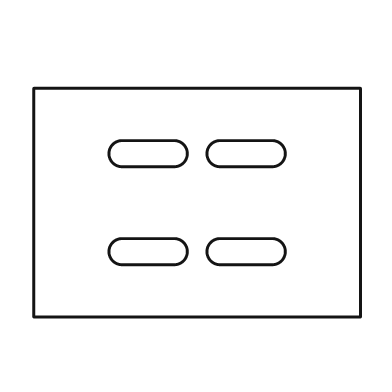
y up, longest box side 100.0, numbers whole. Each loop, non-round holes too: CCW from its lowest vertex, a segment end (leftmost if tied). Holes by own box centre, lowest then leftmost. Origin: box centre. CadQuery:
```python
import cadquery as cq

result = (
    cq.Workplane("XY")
    .moveTo(-50.0, -35.0)
    .lineTo(50.0, -35.0)
    .lineTo(50.0, 35.0)
    .lineTo(-50.0, 35.0)
    .close()
    .moveTo(-23.0, -19.0)
    .lineTo(-7.0, -19.0)
    .threePointArc((-3.0, -15.0), (-7.0, -11.0))
    .lineTo(-23.0, -11.0)
    .threePointArc((-27.0, -15.0), (-23.0, -19.0))
    .close()
    .moveTo(7.0, -19.0)
    .lineTo(23.0, -19.0)
    .threePointArc((27.0, -15.0), (23.0, -11.0))
    .lineTo(7.0, -11.0)
    .threePointArc((3.0, -15.0), (7.0, -19.0))
    .close()
    .moveTo(-23.0, 11.0)
    .lineTo(-7.0, 11.0)
    .threePointArc((-3.0, 15.0), (-7.0, 19.0))
    .lineTo(-23.0, 19.0)
    .threePointArc((-27.0, 15.0), (-23.0, 11.0))
    .close()
    .moveTo(7.0, 11.0)
    .lineTo(23.0, 11.0)
    .threePointArc((27.0, 15.0), (23.0, 19.0))
    .lineTo(7.0, 19.0)
    .threePointArc((3.0, 15.0), (7.0, 11.0))
    .close()
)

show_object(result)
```